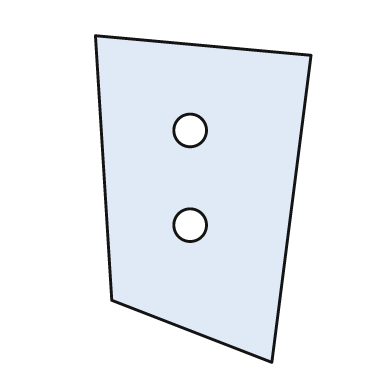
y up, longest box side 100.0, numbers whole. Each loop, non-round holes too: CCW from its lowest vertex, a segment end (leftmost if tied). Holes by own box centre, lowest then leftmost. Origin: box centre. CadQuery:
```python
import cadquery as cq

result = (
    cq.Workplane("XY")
    .moveTo(21.0, -50.0)
    .lineTo(33.0, 44.0)
    .lineTo(-33.0, 50.0)
    .lineTo(-28.0, -31.0)
    .close()
    .moveTo(-4.0, -8.0)
    .circle(5.0)
    .moveTo(-4.0, 21.0)
    .circle(5.0)
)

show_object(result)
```